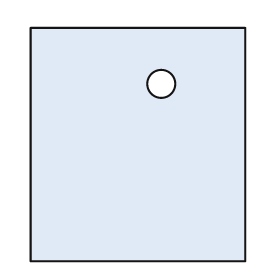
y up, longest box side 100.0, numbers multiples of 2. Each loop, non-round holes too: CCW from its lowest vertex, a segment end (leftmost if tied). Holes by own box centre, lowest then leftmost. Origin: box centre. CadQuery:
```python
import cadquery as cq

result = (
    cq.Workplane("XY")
    .moveTo(-46.0, -50.0)
    .lineTo(46.0, -50.0)
    .lineTo(46.0, 50.0)
    .lineTo(-46.0, 50.0)
    .close()
    .moveTo(10.0, 26.0)
    .circle(6.0)
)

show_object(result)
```